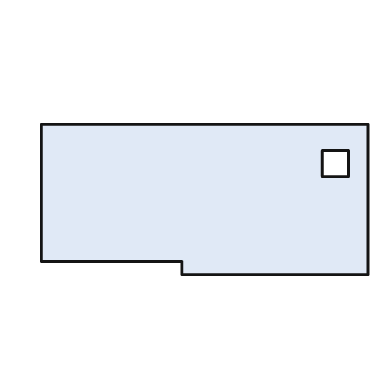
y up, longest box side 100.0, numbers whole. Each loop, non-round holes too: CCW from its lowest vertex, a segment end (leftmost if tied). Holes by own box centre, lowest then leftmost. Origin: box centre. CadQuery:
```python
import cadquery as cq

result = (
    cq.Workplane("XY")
    .moveTo(-7.0, -23.0)
    .lineTo(50.0, -23.0)
    .lineTo(50.0, 23.0)
    .lineTo(-50.0, 23.0)
    .lineTo(-50.0, -19.0)
    .lineTo(-7.0, -19.0)
    .close()
    .moveTo(36.0, 7.0)
    .lineTo(44.0, 7.0)
    .lineTo(44.0, 15.0)
    .lineTo(36.0, 15.0)
    .close()
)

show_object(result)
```